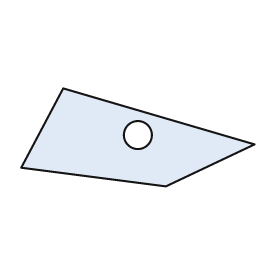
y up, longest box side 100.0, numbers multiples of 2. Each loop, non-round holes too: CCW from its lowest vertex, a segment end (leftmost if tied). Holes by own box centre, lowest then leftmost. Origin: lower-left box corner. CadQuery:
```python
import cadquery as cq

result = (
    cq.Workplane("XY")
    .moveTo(62.0, 0.0)
    .lineTo(100.0, 18.0)
    .lineTo(18.0, 42.0)
    .lineTo(0.0, 8.0)
    .close()
    .moveTo(50.0, 22.0)
    .circle(6.0)
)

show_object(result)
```